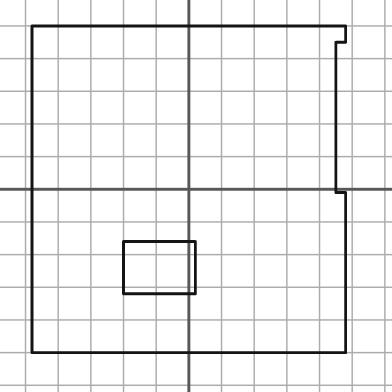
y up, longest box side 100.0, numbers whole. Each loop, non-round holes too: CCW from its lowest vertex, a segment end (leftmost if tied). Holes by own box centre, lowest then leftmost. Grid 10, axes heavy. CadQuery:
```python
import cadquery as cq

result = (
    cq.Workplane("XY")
    .moveTo(-48.0, -50.0)
    .lineTo(48.0, -50.0)
    .lineTo(48.0, -1.0)
    .lineTo(45.0, -1.0)
    .lineTo(45.0, 45.0)
    .lineTo(48.0, 45.0)
    .lineTo(48.0, 50.0)
    .lineTo(-48.0, 50.0)
    .close()
    .moveTo(-20.0, -32.0)
    .lineTo(2.0, -32.0)
    .lineTo(2.0, -16.0)
    .lineTo(-20.0, -16.0)
    .close()
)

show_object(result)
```